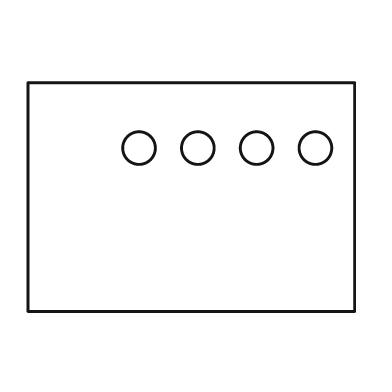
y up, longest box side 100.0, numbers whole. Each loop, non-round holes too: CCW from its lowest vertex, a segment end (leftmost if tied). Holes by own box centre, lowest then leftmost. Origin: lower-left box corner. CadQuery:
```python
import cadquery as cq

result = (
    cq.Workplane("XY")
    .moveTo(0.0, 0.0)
    .lineTo(100.0, 0.0)
    .lineTo(100.0, 70.0)
    .lineTo(0.0, 70.0)
    .close()
    .moveTo(34.0, 50.0)
    .circle(5.0)
    .moveTo(52.0, 50.0)
    .circle(5.0)
    .moveTo(70.0, 50.0)
    .circle(5.0)
    .moveTo(88.0, 50.0)
    .circle(5.0)
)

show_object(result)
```